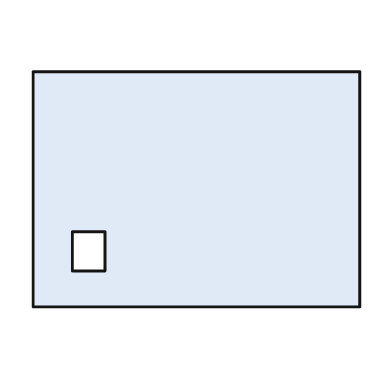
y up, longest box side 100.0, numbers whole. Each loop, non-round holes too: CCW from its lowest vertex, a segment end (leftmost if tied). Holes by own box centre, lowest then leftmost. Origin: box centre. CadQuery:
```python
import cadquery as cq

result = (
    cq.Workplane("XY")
    .moveTo(-50.0, -36.0)
    .lineTo(50.0, -36.0)
    .lineTo(50.0, 36.0)
    .lineTo(-50.0, 36.0)
    .close()
    .moveTo(-38.0, -25.0)
    .lineTo(-28.0, -25.0)
    .lineTo(-28.0, -13.0)
    .lineTo(-38.0, -13.0)
    .close()
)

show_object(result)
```